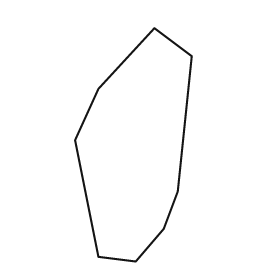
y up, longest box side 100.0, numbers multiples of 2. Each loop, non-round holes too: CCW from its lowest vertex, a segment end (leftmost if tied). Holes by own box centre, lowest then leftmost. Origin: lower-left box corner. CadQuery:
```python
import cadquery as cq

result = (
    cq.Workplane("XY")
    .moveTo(26.0, 0.0)
    .lineTo(38.0, 14.0)
    .lineTo(44.0, 30.0)
    .lineTo(50.0, 88.0)
    .lineTo(34.0, 100.0)
    .lineTo(10.0, 74.0)
    .lineTo(0.0, 52.0)
    .lineTo(10.0, 2.0)
    .close()
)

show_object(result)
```